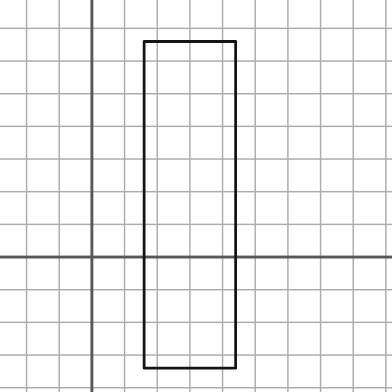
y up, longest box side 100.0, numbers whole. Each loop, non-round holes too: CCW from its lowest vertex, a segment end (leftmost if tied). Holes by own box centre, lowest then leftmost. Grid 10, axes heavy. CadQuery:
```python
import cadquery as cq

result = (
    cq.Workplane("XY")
    .moveTo(16.0, -34.0)
    .lineTo(44.0, -34.0)
    .lineTo(44.0, 66.0)
    .lineTo(16.0, 66.0)
    .close()
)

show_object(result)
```